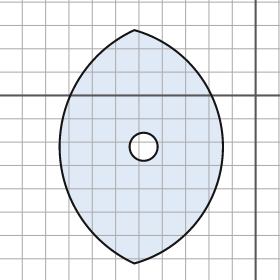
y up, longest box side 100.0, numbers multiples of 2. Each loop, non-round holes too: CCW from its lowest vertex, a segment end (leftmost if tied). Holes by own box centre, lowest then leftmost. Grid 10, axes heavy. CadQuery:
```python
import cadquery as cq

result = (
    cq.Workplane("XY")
    .moveTo(-52.0, -72.0)
    .threePointArc((-14.0, -22.0), (-52.0, 28.0))
    .threePointArc((-84.0, -22.0), (-52.0, -72.0))
    .close()
    .moveTo(-48.0, -22.0)
    .circle(6.0)
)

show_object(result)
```